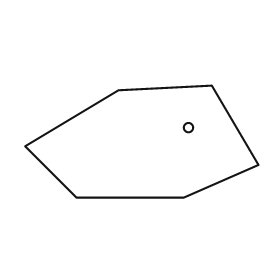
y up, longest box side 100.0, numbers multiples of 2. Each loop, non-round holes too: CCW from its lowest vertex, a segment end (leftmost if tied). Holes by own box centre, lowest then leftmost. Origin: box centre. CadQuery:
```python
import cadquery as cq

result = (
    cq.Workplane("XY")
    .moveTo(-28.0, -24.0)
    .lineTo(18.0, -24.0)
    .lineTo(50.0, -10.0)
    .lineTo(30.0, 24.0)
    .lineTo(-10.0, 22.0)
    .lineTo(-50.0, -2.0)
    .close()
    .moveTo(20.0, 6.0)
    .circle(2.0)
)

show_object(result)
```